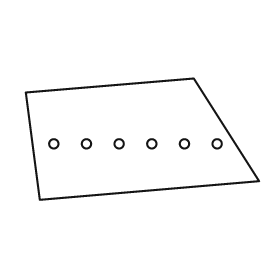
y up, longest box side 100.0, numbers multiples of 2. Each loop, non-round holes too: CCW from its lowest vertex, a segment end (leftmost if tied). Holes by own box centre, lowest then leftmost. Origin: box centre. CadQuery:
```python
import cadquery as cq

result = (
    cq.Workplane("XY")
    .moveTo(-44.0, -26.0)
    .lineTo(50.0, -18.0)
    .lineTo(22.0, 26.0)
    .lineTo(-50.0, 20.0)
    .close()
    .moveTo(-38.0, -2.0)
    .circle(2.0)
    .moveTo(-24.0, -2.0)
    .circle(2.0)
    .moveTo(-10.0, -2.0)
    .circle(2.0)
    .moveTo(4.0, -2.0)
    .circle(2.0)
    .moveTo(18.0, -2.0)
    .circle(2.0)
    .moveTo(32.0, -2.0)
    .circle(2.0)
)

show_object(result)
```